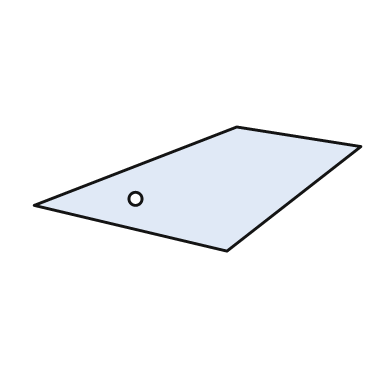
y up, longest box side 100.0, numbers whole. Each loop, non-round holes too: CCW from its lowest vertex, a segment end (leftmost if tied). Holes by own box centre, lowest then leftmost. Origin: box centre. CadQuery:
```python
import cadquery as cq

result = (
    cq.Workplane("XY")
    .moveTo(9.0, -19.0)
    .lineTo(50.0, 13.0)
    .lineTo(12.0, 19.0)
    .lineTo(-50.0, -5.0)
    .close()
    .moveTo(-19.0, -3.0)
    .circle(2.0)
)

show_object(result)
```